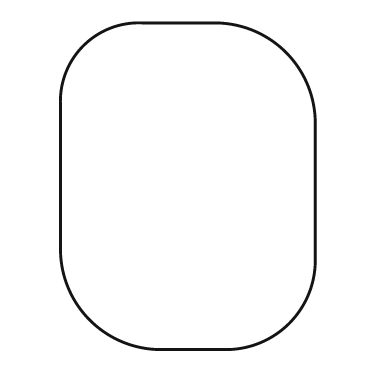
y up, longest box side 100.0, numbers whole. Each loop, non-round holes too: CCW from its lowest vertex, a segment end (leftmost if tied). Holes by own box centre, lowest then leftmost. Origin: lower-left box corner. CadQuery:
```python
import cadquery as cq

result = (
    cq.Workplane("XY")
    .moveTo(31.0, 0.0)
    .lineTo(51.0, 0.0)
    .threePointArc((70.0, 8.0), (78.0, 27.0))
    .lineTo(78.0, 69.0)
    .threePointArc((69.0, 91.0), (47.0, 100.0))
    .lineTo(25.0, 100.0)
    .threePointArc((7.0, 93.0), (0.0, 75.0))
    .lineTo(0.0, 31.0)
    .threePointArc((9.0, 9.0), (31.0, 0.0))
    .close()
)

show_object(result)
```